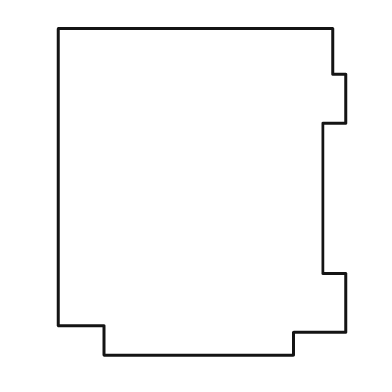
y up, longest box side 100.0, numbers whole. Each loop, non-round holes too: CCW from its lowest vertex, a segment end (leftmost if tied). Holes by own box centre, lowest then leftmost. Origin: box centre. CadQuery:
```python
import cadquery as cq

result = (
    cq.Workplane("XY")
    .moveTo(-30.0, -50.0)
    .lineTo(28.0, -50.0)
    .lineTo(28.0, -43.0)
    .lineTo(44.0, -43.0)
    .lineTo(44.0, -25.0)
    .lineTo(37.0, -25.0)
    .lineTo(37.0, 21.0)
    .lineTo(44.0, 21.0)
    .lineTo(44.0, 36.0)
    .lineTo(40.0, 36.0)
    .lineTo(40.0, 50.0)
    .lineTo(-44.0, 50.0)
    .lineTo(-44.0, -41.0)
    .lineTo(-30.0, -41.0)
    .close()
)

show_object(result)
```